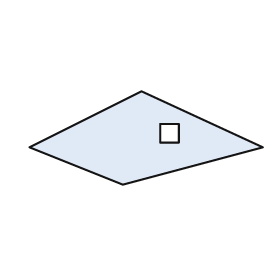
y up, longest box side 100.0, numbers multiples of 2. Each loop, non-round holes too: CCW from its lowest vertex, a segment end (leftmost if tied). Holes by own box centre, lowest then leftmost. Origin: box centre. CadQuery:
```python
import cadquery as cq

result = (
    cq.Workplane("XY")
    .moveTo(-10.0, -20.0)
    .lineTo(50.0, -4.0)
    .lineTo(-2.0, 20.0)
    .lineTo(-50.0, -4.0)
    .close()
    .moveTo(6.0, -2.0)
    .lineTo(14.0, -2.0)
    .lineTo(14.0, 6.0)
    .lineTo(6.0, 6.0)
    .close()
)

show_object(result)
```